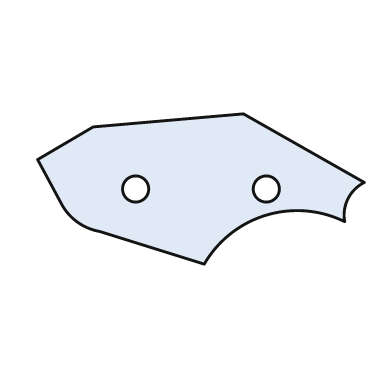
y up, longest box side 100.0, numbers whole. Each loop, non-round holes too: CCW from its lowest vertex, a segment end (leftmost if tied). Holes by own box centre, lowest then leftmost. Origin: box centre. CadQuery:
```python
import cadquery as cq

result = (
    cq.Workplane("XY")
    .moveTo(1.0, -23.0)
    .threePointArc((20.0, -8.0), (44.0, -10.0))
    .threePointArc((45.0, -3.0), (50.0, 2.0))
    .lineTo(13.0, 23.0)
    .lineTo(-33.0, 19.0)
    .lineTo(-50.0, 9.0)
    .lineTo(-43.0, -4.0)
    .threePointArc((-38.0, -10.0), (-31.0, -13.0))
    .close()
    .moveTo(-20.0, 0.0)
    .circle(4.0)
    .moveTo(20.0, 0.0)
    .circle(4.0)
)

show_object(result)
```